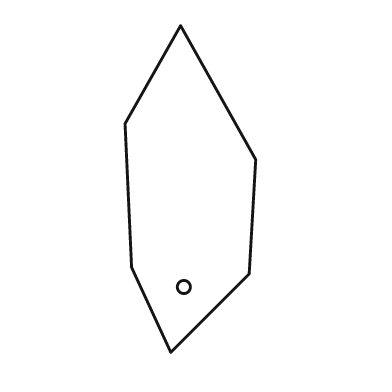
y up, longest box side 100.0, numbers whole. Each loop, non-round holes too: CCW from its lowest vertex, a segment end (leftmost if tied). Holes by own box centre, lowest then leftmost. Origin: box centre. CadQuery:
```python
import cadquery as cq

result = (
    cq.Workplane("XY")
    .moveTo(-6.0, -50.0)
    .lineTo(18.0, -26.0)
    .lineTo(20.0, 9.0)
    .lineTo(-3.0, 50.0)
    .lineTo(-20.0, 20.0)
    .lineTo(-18.0, -24.0)
    .close()
    .moveTo(-2.0, -30.0)
    .circle(2.0)
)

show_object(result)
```